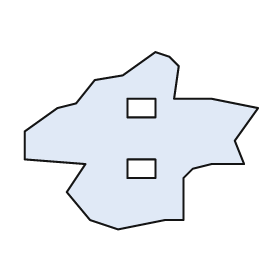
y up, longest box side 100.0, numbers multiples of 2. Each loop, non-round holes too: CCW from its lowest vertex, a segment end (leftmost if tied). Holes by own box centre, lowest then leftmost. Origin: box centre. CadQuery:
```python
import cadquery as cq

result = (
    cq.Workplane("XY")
    .moveTo(-10.0, -38.0)
    .lineTo(10.0, -34.0)
    .lineTo(18.0, -34.0)
    .lineTo(18.0, -16.0)
    .lineTo(22.0, -12.0)
    .lineTo(30.0, -10.0)
    .lineTo(44.0, -10.0)
    .lineTo(40.0, 0.0)
    .lineTo(50.0, 14.0)
    .lineTo(30.0, 18.0)
    .lineTo(14.0, 18.0)
    .lineTo(16.0, 32.0)
    .lineTo(12.0, 36.0)
    .lineTo(6.0, 38.0)
    .lineTo(-8.0, 28.0)
    .lineTo(-20.0, 26.0)
    .lineTo(-28.0, 16.0)
    .lineTo(-36.0, 14.0)
    .lineTo(-50.0, 4.0)
    .lineTo(-50.0, -8.0)
    .lineTo(-24.0, -10.0)
    .lineTo(-32.0, -22.0)
    .lineTo(-22.0, -34.0)
    .close()
    .moveTo(-6.0, -16.0)
    .lineTo(6.0, -16.0)
    .lineTo(6.0, -8.0)
    .lineTo(-6.0, -8.0)
    .close()
    .moveTo(-6.0, 10.0)
    .lineTo(6.0, 10.0)
    .lineTo(6.0, 18.0)
    .lineTo(-6.0, 18.0)
    .close()
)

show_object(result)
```